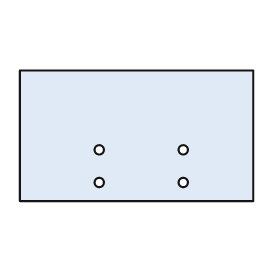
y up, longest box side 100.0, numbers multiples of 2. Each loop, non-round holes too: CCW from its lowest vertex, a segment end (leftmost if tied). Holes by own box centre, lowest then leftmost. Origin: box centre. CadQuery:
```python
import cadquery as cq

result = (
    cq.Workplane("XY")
    .moveTo(-50.0, -28.0)
    .lineTo(50.0, -28.0)
    .lineTo(50.0, 28.0)
    .lineTo(-50.0, 28.0)
    .close()
    .moveTo(-16.0, -20.0)
    .circle(2.0)
    .moveTo(20.0, -20.0)
    .circle(2.0)
    .moveTo(-16.0, -6.0)
    .circle(2.0)
    .moveTo(20.0, -6.0)
    .circle(2.0)
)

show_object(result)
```